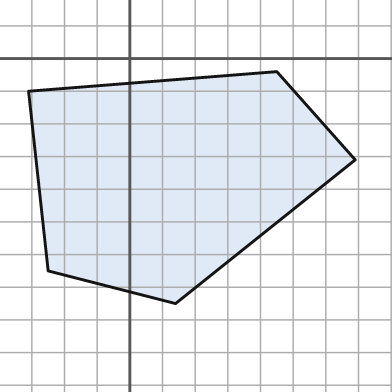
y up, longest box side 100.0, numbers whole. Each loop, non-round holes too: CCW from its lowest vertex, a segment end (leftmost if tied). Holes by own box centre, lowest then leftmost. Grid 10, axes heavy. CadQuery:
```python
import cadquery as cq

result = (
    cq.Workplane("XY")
    .moveTo(14.0, -75.0)
    .lineTo(69.0, -31.0)
    .lineTo(45.0, -4.0)
    .lineTo(-31.0, -10.0)
    .lineTo(-25.0, -65.0)
    .close()
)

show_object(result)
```